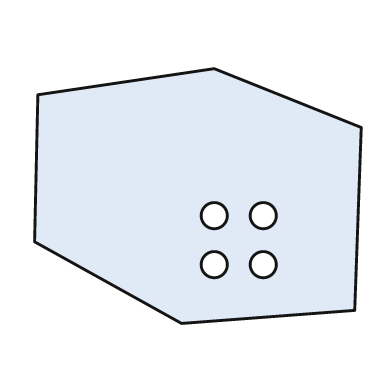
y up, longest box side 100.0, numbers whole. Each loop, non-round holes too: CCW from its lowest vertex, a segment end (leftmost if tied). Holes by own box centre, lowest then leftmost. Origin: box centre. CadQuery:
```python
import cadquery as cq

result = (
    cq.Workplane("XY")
    .moveTo(-5.0, -39.0)
    .lineTo(48.0, -35.0)
    .lineTo(50.0, 21.0)
    .lineTo(5.0, 39.0)
    .lineTo(-49.0, 31.0)
    .lineTo(-50.0, -14.0)
    .close()
    .moveTo(5.0, -21.0)
    .circle(4.0)
    .moveTo(20.0, -21.0)
    .circle(4.0)
    .moveTo(5.0, -6.0)
    .circle(4.0)
    .moveTo(20.0, -6.0)
    .circle(4.0)
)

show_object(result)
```